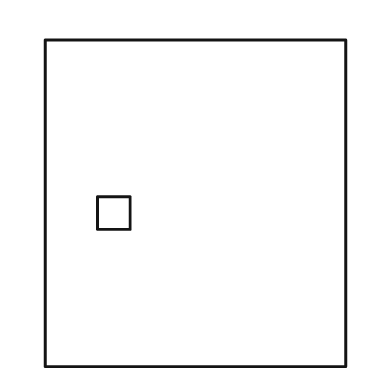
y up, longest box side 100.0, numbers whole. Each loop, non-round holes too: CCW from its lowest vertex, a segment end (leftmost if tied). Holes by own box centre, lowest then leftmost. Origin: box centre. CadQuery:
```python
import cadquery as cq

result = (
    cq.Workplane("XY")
    .moveTo(-46.0, -50.0)
    .lineTo(46.0, -50.0)
    .lineTo(46.0, 50.0)
    .lineTo(-46.0, 50.0)
    .close()
    .moveTo(-30.0, -8.0)
    .lineTo(-20.0, -8.0)
    .lineTo(-20.0, 2.0)
    .lineTo(-30.0, 2.0)
    .close()
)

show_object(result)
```